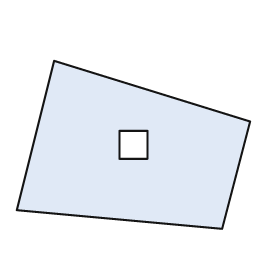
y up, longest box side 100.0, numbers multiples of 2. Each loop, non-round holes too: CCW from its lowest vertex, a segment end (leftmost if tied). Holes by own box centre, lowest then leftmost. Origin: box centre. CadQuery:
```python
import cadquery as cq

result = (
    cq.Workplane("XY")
    .moveTo(38.0, -36.0)
    .lineTo(50.0, 10.0)
    .lineTo(-34.0, 36.0)
    .lineTo(-50.0, -28.0)
    .close()
    .moveTo(-6.0, -6.0)
    .lineTo(6.0, -6.0)
    .lineTo(6.0, 6.0)
    .lineTo(-6.0, 6.0)
    .close()
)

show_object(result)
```